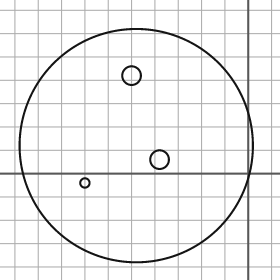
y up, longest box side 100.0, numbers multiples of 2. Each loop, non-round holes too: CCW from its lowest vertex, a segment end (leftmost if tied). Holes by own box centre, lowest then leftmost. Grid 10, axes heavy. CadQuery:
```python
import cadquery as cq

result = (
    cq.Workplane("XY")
    .moveTo(-48.0, 12.0)
    .circle(50.0)
    .moveTo(-70.0, -4.0)
    .circle(2.0)
    .moveTo(-38.0, 6.0)
    .circle(4.0)
    .moveTo(-50.0, 42.0)
    .circle(4.0)
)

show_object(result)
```